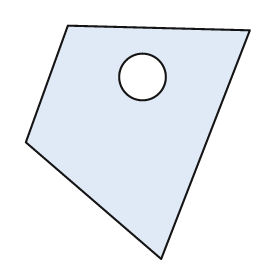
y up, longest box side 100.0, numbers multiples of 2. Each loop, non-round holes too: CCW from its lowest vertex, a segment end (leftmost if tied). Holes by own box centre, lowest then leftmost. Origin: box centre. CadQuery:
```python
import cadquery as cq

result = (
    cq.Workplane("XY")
    .moveTo(10.0, -50.0)
    .lineTo(48.0, 48.0)
    .lineTo(-30.0, 50.0)
    .lineTo(-48.0, 0.0)
    .close()
    .moveTo(2.0, 28.0)
    .circle(10.0)
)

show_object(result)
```